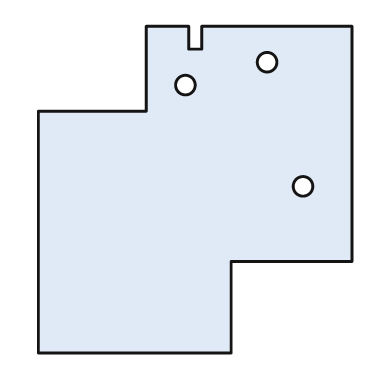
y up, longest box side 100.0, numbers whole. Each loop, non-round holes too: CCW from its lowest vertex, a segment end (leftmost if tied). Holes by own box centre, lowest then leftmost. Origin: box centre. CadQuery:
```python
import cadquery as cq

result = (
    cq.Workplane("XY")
    .moveTo(-48.0, -50.0)
    .lineTo(11.0, -50.0)
    .lineTo(11.0, -22.0)
    .lineTo(48.0, -22.0)
    .lineTo(48.0, 50.0)
    .lineTo(2.0, 50.0)
    .lineTo(2.0, 43.0)
    .lineTo(-2.0, 43.0)
    .lineTo(-2.0, 50.0)
    .lineTo(-15.0, 50.0)
    .lineTo(-15.0, 24.0)
    .lineTo(-48.0, 24.0)
    .close()
    .moveTo(33.0, 1.0)
    .circle(3.0)
    .moveTo(-3.0, 32.0)
    .circle(3.0)
    .moveTo(22.0, 39.0)
    .circle(3.0)
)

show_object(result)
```